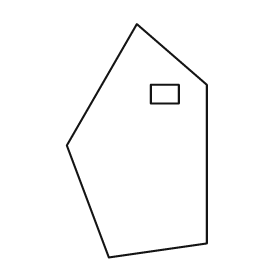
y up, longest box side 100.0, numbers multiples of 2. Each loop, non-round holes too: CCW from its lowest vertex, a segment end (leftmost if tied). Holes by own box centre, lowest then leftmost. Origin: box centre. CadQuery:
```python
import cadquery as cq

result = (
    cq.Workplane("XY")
    .moveTo(-12.0, -50.0)
    .lineTo(30.0, -44.0)
    .lineTo(30.0, 24.0)
    .lineTo(0.0, 50.0)
    .lineTo(-30.0, -2.0)
    .close()
    .moveTo(6.0, 16.0)
    .lineTo(18.0, 16.0)
    .lineTo(18.0, 24.0)
    .lineTo(6.0, 24.0)
    .close()
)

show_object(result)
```